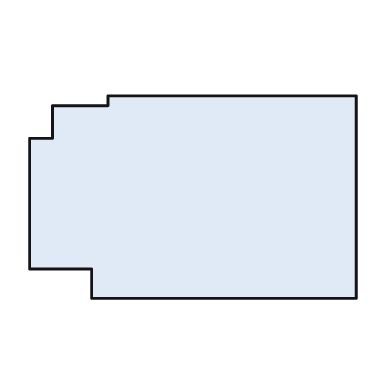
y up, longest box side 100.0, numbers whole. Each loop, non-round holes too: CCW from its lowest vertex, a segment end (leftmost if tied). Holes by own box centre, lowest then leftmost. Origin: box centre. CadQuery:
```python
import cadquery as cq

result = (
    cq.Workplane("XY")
    .moveTo(-31.0, -31.0)
    .lineTo(50.0, -31.0)
    .lineTo(50.0, 31.0)
    .lineTo(-26.0, 31.0)
    .lineTo(-26.0, 28.0)
    .lineTo(-43.0, 28.0)
    .lineTo(-43.0, 18.0)
    .lineTo(-50.0, 18.0)
    .lineTo(-50.0, -22.0)
    .lineTo(-31.0, -22.0)
    .close()
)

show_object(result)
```